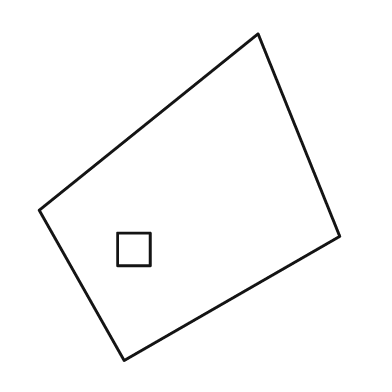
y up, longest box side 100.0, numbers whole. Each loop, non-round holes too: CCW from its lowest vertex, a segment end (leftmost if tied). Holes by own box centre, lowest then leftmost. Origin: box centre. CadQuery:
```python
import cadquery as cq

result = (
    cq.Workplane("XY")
    .moveTo(-20.0, -50.0)
    .lineTo(46.0, -12.0)
    .lineTo(21.0, 50.0)
    .lineTo(-46.0, -4.0)
    .close()
    .moveTo(-22.0, -21.0)
    .lineTo(-12.0, -21.0)
    .lineTo(-12.0, -11.0)
    .lineTo(-22.0, -11.0)
    .close()
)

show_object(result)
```